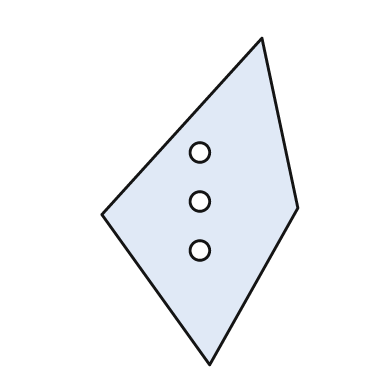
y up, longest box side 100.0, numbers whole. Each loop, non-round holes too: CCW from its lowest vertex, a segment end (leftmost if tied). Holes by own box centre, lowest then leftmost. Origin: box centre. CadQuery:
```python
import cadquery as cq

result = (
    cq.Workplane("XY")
    .moveTo(3.0, -50.0)
    .lineTo(30.0, -2.0)
    .lineTo(19.0, 50.0)
    .lineTo(-30.0, -4.0)
    .close()
    .moveTo(0.0, -15.0)
    .circle(3.0)
    .moveTo(0.0, 0.0)
    .circle(3.0)
    .moveTo(0.0, 15.0)
    .circle(3.0)
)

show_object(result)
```